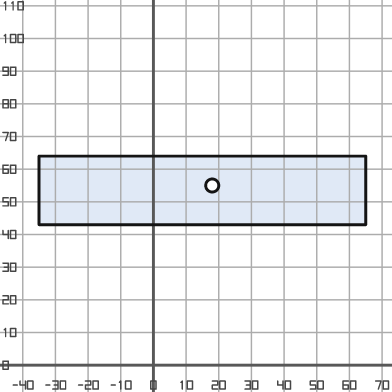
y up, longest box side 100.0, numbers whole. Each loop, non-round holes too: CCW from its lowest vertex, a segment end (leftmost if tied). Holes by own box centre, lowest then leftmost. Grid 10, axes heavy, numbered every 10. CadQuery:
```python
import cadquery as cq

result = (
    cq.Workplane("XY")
    .moveTo(-35.0, 43.0)
    .lineTo(65.0, 43.0)
    .lineTo(65.0, 64.0)
    .lineTo(-35.0, 64.0)
    .close()
    .moveTo(18.0, 55.0)
    .circle(2.0)
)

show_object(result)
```